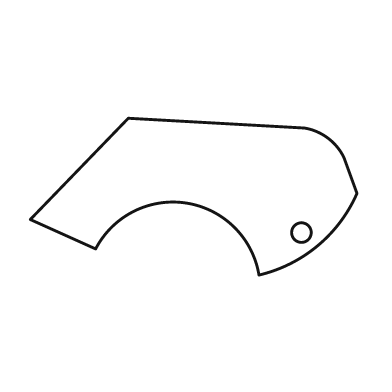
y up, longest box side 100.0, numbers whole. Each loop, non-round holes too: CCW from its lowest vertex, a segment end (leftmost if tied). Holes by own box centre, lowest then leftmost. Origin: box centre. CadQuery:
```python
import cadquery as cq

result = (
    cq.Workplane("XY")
    .moveTo(20.0, -24.0)
    .threePointArc((38.0, -15.0), (50.0, 1.0))
    .lineTo(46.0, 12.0)
    .threePointArc((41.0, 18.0), (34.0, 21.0))
    .lineTo(-20.0, 24.0)
    .lineTo(-50.0, -7.0)
    .lineTo(-30.0, -16.0)
    .threePointArc((-2.0, -2.0), (20.0, -24.0))
    .close()
    .moveTo(33.0, -11.0)
    .circle(3.0)
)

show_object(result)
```